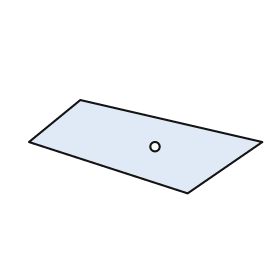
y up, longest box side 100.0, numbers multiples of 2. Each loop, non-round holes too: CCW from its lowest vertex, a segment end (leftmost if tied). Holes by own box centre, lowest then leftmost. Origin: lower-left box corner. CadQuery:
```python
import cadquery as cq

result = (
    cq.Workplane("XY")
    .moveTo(68.0, 0.0)
    .lineTo(100.0, 22.0)
    .lineTo(22.0, 40.0)
    .lineTo(0.0, 22.0)
    .close()
    .moveTo(54.0, 20.0)
    .circle(2.0)
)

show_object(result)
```